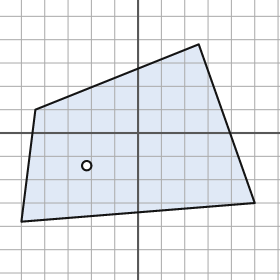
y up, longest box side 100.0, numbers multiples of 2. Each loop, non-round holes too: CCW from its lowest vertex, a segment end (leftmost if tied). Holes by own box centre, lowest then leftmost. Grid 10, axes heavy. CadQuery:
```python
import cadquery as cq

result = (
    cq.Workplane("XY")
    .moveTo(-50.0, -38.0)
    .lineTo(50.0, -30.0)
    .lineTo(26.0, 38.0)
    .lineTo(-44.0, 10.0)
    .close()
    .moveTo(-22.0, -14.0)
    .circle(2.0)
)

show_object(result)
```